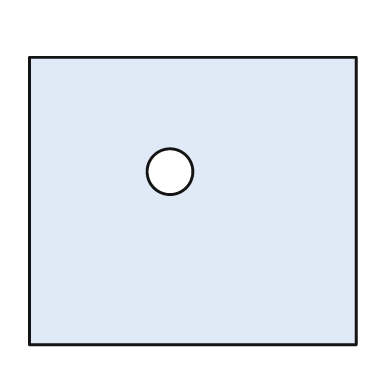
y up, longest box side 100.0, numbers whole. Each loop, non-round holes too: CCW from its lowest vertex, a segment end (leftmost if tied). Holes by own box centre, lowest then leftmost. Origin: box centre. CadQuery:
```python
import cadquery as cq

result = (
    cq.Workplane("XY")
    .moveTo(-50.0, -44.0)
    .lineTo(50.0, -44.0)
    .lineTo(50.0, 44.0)
    .lineTo(-50.0, 44.0)
    .close()
    .moveTo(-7.0, 9.0)
    .circle(7.0)
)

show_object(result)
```